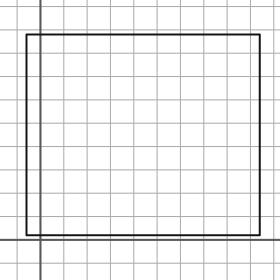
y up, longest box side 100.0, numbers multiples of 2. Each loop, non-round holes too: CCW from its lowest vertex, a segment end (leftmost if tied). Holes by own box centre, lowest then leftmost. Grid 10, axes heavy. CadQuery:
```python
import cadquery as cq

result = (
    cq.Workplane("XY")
    .moveTo(-6.0, 2.0)
    .lineTo(94.0, 2.0)
    .lineTo(94.0, 88.0)
    .lineTo(-6.0, 88.0)
    .close()
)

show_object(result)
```